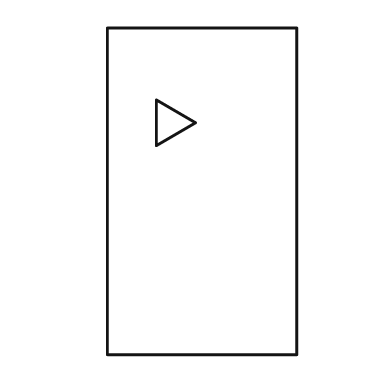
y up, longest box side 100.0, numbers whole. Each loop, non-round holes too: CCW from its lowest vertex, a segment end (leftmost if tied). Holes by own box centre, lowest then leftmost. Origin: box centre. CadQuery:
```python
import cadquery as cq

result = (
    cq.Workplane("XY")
    .moveTo(-29.0, -50.0)
    .lineTo(29.0, -50.0)
    .lineTo(29.0, 50.0)
    .lineTo(-29.0, 50.0)
    .close()
    .moveTo(-14.0, 14.0)
    .lineTo(-2.0, 21.0)
    .lineTo(-14.0, 28.0)
    .close()
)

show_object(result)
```